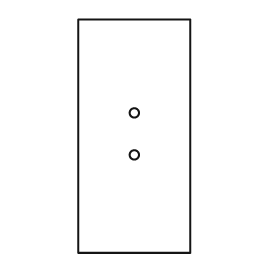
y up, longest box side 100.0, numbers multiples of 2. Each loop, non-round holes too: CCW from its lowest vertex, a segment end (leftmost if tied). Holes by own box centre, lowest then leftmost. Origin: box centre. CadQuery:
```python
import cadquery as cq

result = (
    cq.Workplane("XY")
    .moveTo(-24.0, -50.0)
    .lineTo(24.0, -50.0)
    .lineTo(24.0, 50.0)
    .lineTo(-24.0, 50.0)
    .close()
    .moveTo(0.0, -8.0)
    .circle(2.0)
    .moveTo(0.0, 10.0)
    .circle(2.0)
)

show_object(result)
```